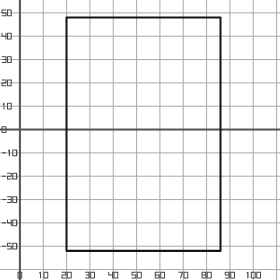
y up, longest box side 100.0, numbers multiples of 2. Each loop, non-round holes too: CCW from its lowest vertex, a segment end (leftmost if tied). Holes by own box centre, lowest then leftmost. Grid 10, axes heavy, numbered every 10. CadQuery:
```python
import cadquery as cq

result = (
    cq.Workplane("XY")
    .moveTo(20.0, -52.0)
    .lineTo(86.0, -52.0)
    .lineTo(86.0, 48.0)
    .lineTo(20.0, 48.0)
    .close()
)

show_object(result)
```